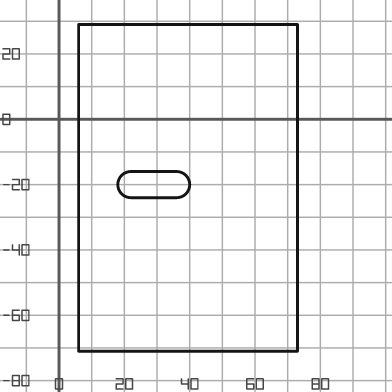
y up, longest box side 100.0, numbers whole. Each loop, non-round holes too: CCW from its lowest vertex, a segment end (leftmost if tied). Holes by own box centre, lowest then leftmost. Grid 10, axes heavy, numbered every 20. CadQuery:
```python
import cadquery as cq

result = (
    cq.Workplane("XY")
    .moveTo(6.0, -71.0)
    .lineTo(73.0, -71.0)
    .lineTo(73.0, 29.0)
    .lineTo(6.0, 29.0)
    .close()
    .moveTo(22.0, -24.0)
    .lineTo(36.0, -24.0)
    .threePointArc((40.0, -20.0), (36.0, -16.0))
    .lineTo(22.0, -16.0)
    .threePointArc((18.0, -20.0), (22.0, -24.0))
    .close()
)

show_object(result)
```